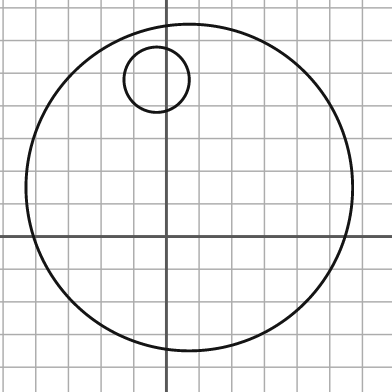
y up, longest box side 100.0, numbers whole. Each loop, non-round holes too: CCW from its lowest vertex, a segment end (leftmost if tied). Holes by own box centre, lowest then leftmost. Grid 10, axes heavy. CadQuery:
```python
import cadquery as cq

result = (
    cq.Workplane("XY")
    .moveTo(7.0, 15.0)
    .circle(50.0)
    .moveTo(-3.0, 48.0)
    .circle(10.0)
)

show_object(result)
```